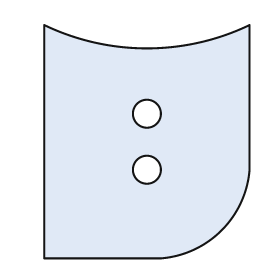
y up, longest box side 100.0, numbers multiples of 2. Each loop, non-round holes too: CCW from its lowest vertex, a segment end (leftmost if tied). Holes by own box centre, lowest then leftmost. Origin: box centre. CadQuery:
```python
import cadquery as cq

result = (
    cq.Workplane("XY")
    .moveTo(-44.0, -50.0)
    .lineTo(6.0, -50.0)
    .threePointArc((32.0, -38.0), (44.0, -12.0))
    .lineTo(44.0, 50.0)
    .threePointArc((0.0, 40.0), (-44.0, 50.0))
    .close()
    .moveTo(0.0, -12.0)
    .circle(6.0)
    .moveTo(0.0, 12.0)
    .circle(6.0)
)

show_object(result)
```